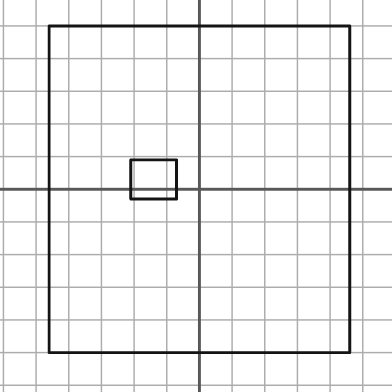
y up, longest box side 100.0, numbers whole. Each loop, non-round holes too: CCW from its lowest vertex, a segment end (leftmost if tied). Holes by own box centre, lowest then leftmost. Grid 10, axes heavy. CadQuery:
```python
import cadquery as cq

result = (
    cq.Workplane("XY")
    .moveTo(-46.0, -50.0)
    .lineTo(46.0, -50.0)
    .lineTo(46.0, 50.0)
    .lineTo(-46.0, 50.0)
    .close()
    .moveTo(-21.0, -3.0)
    .lineTo(-7.0, -3.0)
    .lineTo(-7.0, 9.0)
    .lineTo(-21.0, 9.0)
    .close()
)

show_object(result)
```